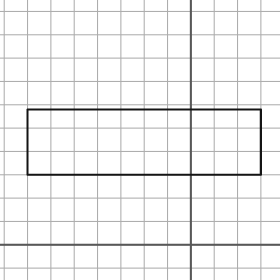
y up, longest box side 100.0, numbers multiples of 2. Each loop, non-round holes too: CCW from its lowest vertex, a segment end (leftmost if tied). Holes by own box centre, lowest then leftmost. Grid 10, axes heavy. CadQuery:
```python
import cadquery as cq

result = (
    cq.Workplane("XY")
    .moveTo(-70.0, 30.0)
    .lineTo(30.0, 30.0)
    .lineTo(30.0, 58.0)
    .lineTo(-70.0, 58.0)
    .close()
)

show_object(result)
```